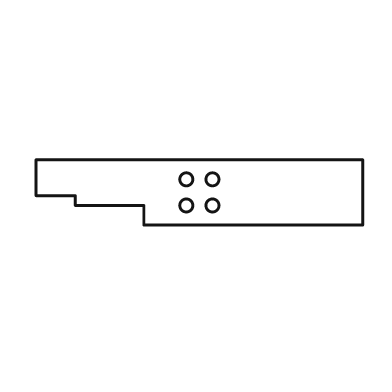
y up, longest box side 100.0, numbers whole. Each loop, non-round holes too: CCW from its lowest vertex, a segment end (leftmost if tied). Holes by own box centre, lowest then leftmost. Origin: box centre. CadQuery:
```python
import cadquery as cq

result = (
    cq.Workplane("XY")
    .moveTo(-17.0, -10.0)
    .lineTo(50.0, -10.0)
    .lineTo(50.0, 10.0)
    .lineTo(-50.0, 10.0)
    .lineTo(-50.0, -1.0)
    .lineTo(-38.0, -1.0)
    .lineTo(-38.0, -4.0)
    .lineTo(-17.0, -4.0)
    .close()
    .moveTo(-4.0, -4.0)
    .circle(2.0)
    .moveTo(4.0, -4.0)
    .circle(2.0)
    .moveTo(-4.0, 4.0)
    .circle(2.0)
    .moveTo(4.0, 4.0)
    .circle(2.0)
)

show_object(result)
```